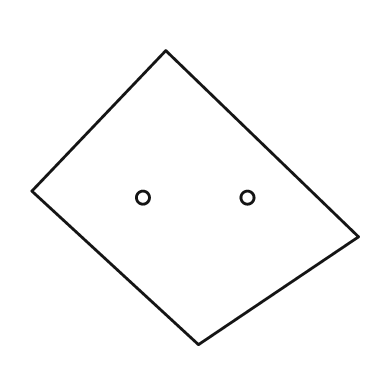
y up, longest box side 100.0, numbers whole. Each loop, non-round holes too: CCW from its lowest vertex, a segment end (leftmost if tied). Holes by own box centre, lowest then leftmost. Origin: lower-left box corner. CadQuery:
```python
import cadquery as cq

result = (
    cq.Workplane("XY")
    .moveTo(51.0, 0.0)
    .lineTo(100.0, 33.0)
    .lineTo(41.0, 90.0)
    .lineTo(0.0, 47.0)
    .close()
    .moveTo(34.0, 45.0)
    .circle(2.0)
    .moveTo(66.0, 45.0)
    .circle(2.0)
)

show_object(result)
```